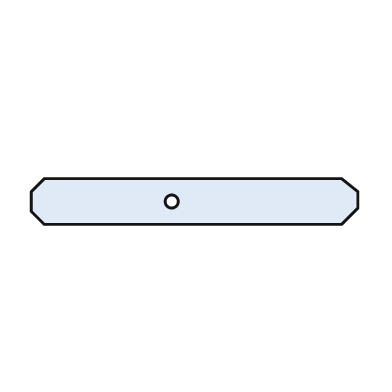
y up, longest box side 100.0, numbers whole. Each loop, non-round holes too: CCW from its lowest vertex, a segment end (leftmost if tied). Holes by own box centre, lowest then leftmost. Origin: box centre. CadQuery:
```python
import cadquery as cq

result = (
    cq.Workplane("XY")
    .moveTo(-46.0, -7.0)
    .lineTo(45.0, -7.0)
    .lineTo(50.0, -2.0)
    .lineTo(50.0, 3.0)
    .lineTo(45.0, 7.0)
    .lineTo(-46.0, 7.0)
    .lineTo(-50.0, 3.0)
    .lineTo(-50.0, -3.0)
    .close()
    .moveTo(-7.0, 0.0)
    .circle(2.0)
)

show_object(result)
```